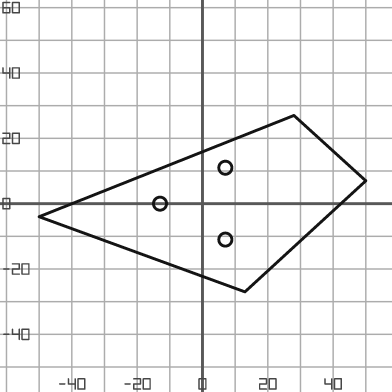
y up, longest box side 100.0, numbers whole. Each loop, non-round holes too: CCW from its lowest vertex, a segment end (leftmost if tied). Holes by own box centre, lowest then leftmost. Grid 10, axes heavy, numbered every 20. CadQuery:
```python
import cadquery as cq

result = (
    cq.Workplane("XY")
    .moveTo(13.0, -27.0)
    .lineTo(50.0, 7.0)
    .lineTo(28.0, 27.0)
    .lineTo(-50.0, -4.0)
    .close()
    .moveTo(7.0, -11.0)
    .circle(2.0)
    .moveTo(-13.0, 0.0)
    .circle(2.0)
    .moveTo(7.0, 11.0)
    .circle(2.0)
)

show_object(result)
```